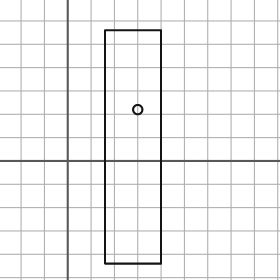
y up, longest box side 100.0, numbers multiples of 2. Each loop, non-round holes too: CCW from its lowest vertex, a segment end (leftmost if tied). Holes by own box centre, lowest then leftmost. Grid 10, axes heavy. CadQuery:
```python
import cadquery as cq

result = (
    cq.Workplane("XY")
    .moveTo(16.0, -44.0)
    .lineTo(40.0, -44.0)
    .lineTo(40.0, 56.0)
    .lineTo(16.0, 56.0)
    .close()
    .moveTo(30.0, 22.0)
    .circle(2.0)
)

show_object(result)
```